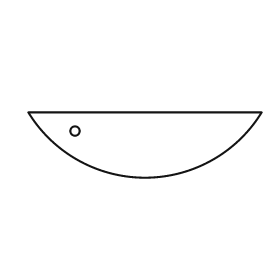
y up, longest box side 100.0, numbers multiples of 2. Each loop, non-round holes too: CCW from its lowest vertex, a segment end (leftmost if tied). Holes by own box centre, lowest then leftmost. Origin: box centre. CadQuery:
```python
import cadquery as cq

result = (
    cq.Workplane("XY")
    .moveTo(-50.0, 14.0)
    .threePointArc((0.0, -14.0), (50.0, 14.0))
    .close()
    .moveTo(-30.0, 6.0)
    .circle(2.0)
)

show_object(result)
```